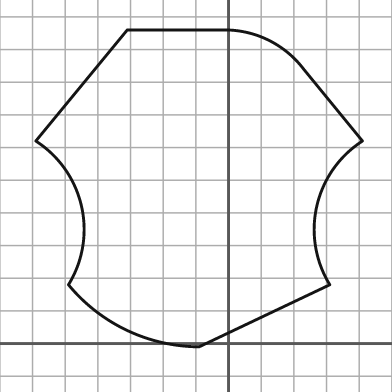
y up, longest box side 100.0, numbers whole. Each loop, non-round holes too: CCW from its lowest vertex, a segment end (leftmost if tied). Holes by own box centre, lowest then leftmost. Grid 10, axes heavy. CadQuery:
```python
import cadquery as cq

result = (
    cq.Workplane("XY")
    .moveTo(-9.0, -1.0)
    .lineTo(31.0, 18.0)
    .threePointArc((27.0, 42.0), (41.0, 62.0))
    .lineTo(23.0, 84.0)
    .threePointArc((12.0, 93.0), (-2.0, 96.0))
    .lineTo(-31.0, 96.0)
    .lineTo(-59.0, 62.0)
    .threePointArc((-45.0, 42.0), (-49.0, 18.0))
    .threePointArc((-31.0, 4.0), (-9.0, -1.0))
    .close()
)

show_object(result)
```